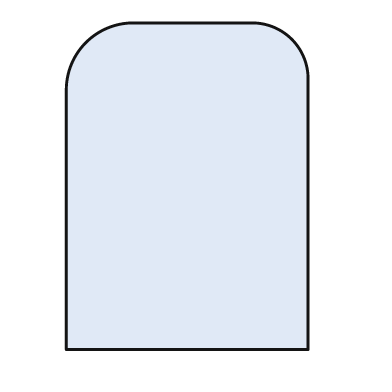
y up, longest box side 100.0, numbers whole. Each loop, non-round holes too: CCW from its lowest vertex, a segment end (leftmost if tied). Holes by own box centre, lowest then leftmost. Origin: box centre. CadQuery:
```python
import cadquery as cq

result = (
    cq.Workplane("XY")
    .moveTo(-37.0, -50.0)
    .lineTo(37.0, -50.0)
    .lineTo(37.0, 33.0)
    .threePointArc((32.0, 45.0), (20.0, 50.0))
    .lineTo(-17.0, 50.0)
    .threePointArc((-31.0, 44.0), (-37.0, 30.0))
    .close()
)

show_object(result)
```